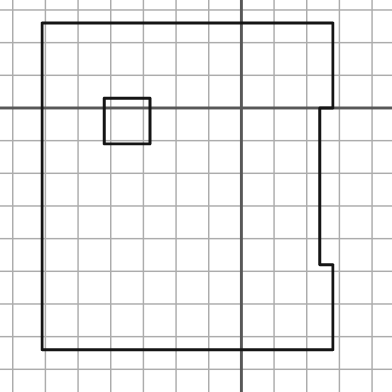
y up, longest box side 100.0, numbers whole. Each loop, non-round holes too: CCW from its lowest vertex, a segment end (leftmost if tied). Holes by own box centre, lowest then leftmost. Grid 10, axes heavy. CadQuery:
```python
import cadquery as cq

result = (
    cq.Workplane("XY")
    .moveTo(-61.0, -74.0)
    .lineTo(28.0, -74.0)
    .lineTo(28.0, -48.0)
    .lineTo(24.0, -48.0)
    .lineTo(24.0, 0.0)
    .lineTo(28.0, 0.0)
    .lineTo(28.0, 26.0)
    .lineTo(-61.0, 26.0)
    .close()
    .moveTo(-42.0, -11.0)
    .lineTo(-28.0, -11.0)
    .lineTo(-28.0, 3.0)
    .lineTo(-42.0, 3.0)
    .close()
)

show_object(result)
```